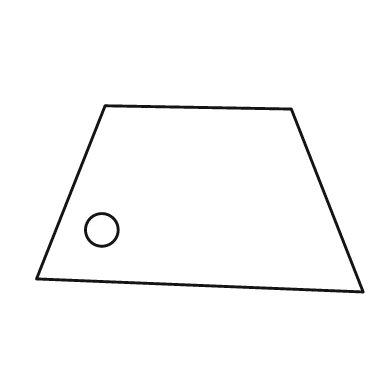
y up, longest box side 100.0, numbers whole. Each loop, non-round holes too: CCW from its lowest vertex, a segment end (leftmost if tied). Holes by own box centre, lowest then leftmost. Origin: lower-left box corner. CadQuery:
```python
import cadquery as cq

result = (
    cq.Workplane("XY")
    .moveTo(100.0, 0.0)
    .lineTo(78.0, 56.0)
    .lineTo(21.0, 57.0)
    .lineTo(0.0, 4.0)
    .close()
    .moveTo(20.0, 19.0)
    .circle(5.0)
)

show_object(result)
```